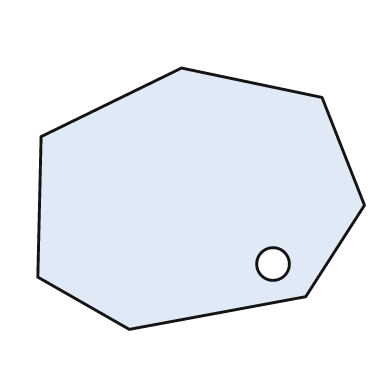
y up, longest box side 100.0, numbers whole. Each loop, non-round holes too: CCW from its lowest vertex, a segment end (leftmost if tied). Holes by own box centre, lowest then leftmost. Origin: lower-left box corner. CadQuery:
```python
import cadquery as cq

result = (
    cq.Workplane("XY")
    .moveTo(28.0, 0.0)
    .lineTo(82.0, 10.0)
    .lineTo(100.0, 38.0)
    .lineTo(87.0, 71.0)
    .lineTo(44.0, 80.0)
    .lineTo(1.0, 59.0)
    .lineTo(0.0, 16.0)
    .close()
    .moveTo(72.0, 20.0)
    .circle(5.0)
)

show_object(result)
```